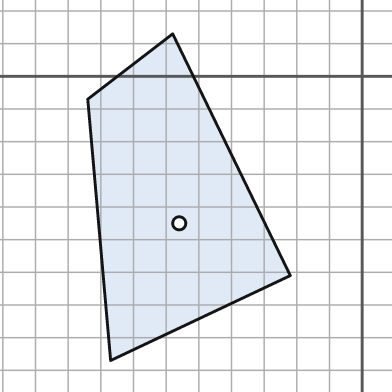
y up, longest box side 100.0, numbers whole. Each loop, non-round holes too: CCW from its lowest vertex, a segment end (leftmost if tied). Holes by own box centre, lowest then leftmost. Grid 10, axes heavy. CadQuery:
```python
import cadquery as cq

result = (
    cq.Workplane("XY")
    .moveTo(-77.0, -87.0)
    .lineTo(-22.0, -61.0)
    .lineTo(-58.0, 13.0)
    .lineTo(-84.0, -7.0)
    .close()
    .moveTo(-56.0, -45.0)
    .circle(2.0)
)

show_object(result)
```